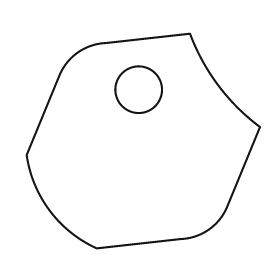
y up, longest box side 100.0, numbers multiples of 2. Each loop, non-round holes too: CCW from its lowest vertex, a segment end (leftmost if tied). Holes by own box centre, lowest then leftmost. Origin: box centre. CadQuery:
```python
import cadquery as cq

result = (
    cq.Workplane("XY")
    .moveTo(-20.0, -46.0)
    .lineTo(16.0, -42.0)
    .threePointArc((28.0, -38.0), (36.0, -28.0))
    .lineTo(50.0, 6.0)
    .threePointArc((32.0, 24.0), (20.0, 46.0))
    .lineTo(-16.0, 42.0)
    .threePointArc((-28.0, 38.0), (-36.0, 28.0))
    .lineTo(-50.0, -6.0)
    .threePointArc((-40.0, -30.0), (-20.0, -46.0))
    .close()
    .moveTo(-2.0, 22.0)
    .circle(10.0)
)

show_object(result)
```